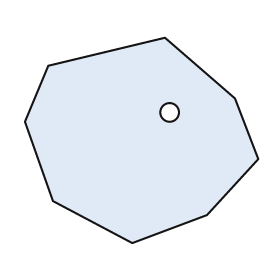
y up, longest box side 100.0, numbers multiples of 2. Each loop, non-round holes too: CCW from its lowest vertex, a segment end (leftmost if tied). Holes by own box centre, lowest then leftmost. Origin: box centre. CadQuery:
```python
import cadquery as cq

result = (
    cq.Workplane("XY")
    .moveTo(-4.0, -44.0)
    .lineTo(28.0, -32.0)
    .lineTo(50.0, -8.0)
    .lineTo(40.0, 18.0)
    .lineTo(10.0, 44.0)
    .lineTo(-40.0, 32.0)
    .lineTo(-50.0, 8.0)
    .lineTo(-38.0, -26.0)
    .close()
    .moveTo(12.0, 12.0)
    .circle(4.0)
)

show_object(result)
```